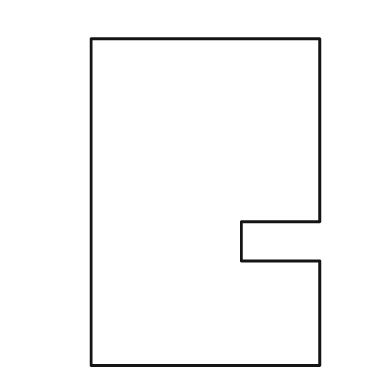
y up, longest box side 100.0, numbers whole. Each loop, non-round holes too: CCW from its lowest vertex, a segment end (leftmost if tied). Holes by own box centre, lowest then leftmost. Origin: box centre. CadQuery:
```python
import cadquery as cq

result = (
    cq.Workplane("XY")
    .moveTo(-35.0, -50.0)
    .lineTo(35.0, -50.0)
    .lineTo(35.0, -18.0)
    .lineTo(11.0, -18.0)
    .lineTo(11.0, -6.0)
    .lineTo(35.0, -6.0)
    .lineTo(35.0, 50.0)
    .lineTo(-35.0, 50.0)
    .close()
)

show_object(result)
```